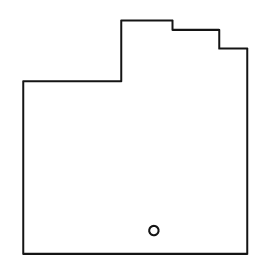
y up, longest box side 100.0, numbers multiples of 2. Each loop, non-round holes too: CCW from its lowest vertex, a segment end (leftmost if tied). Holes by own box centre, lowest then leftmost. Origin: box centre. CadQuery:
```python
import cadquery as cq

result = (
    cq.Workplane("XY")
    .moveTo(-48.0, -50.0)
    .lineTo(48.0, -50.0)
    .lineTo(48.0, 38.0)
    .lineTo(36.0, 38.0)
    .lineTo(36.0, 46.0)
    .lineTo(16.0, 46.0)
    .lineTo(16.0, 50.0)
    .lineTo(-6.0, 50.0)
    .lineTo(-6.0, 24.0)
    .lineTo(-48.0, 24.0)
    .close()
    .moveTo(8.0, -40.0)
    .circle(2.0)
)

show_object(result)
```